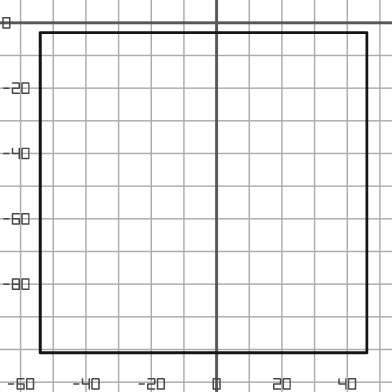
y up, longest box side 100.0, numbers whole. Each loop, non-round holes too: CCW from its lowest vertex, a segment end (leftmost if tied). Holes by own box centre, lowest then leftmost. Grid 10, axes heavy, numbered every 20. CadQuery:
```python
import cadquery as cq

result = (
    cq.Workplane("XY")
    .moveTo(-54.0, -101.0)
    .lineTo(46.0, -101.0)
    .lineTo(46.0, -3.0)
    .lineTo(-54.0, -3.0)
    .close()
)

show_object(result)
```